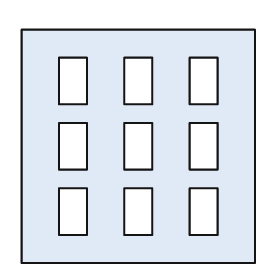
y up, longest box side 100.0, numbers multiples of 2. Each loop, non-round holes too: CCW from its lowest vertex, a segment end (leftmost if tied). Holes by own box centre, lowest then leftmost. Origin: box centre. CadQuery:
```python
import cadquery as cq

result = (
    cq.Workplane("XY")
    .moveTo(-50.0, -50.0)
    .lineTo(50.0, -50.0)
    .lineTo(50.0, 50.0)
    .lineTo(-50.0, 50.0)
    .close()
    .moveTo(-34.0, -38.0)
    .lineTo(-22.0, -38.0)
    .lineTo(-22.0, -18.0)
    .lineTo(-34.0, -18.0)
    .close()
    .moveTo(-6.0, -38.0)
    .lineTo(6.0, -38.0)
    .lineTo(6.0, -18.0)
    .lineTo(-6.0, -18.0)
    .close()
    .moveTo(22.0, -38.0)
    .lineTo(34.0, -38.0)
    .lineTo(34.0, -18.0)
    .lineTo(22.0, -18.0)
    .close()
    .moveTo(-34.0, -10.0)
    .lineTo(-22.0, -10.0)
    .lineTo(-22.0, 10.0)
    .lineTo(-34.0, 10.0)
    .close()
    .moveTo(-6.0, -10.0)
    .lineTo(6.0, -10.0)
    .lineTo(6.0, 10.0)
    .lineTo(-6.0, 10.0)
    .close()
    .moveTo(22.0, -10.0)
    .lineTo(34.0, -10.0)
    .lineTo(34.0, 10.0)
    .lineTo(22.0, 10.0)
    .close()
    .moveTo(-34.0, 18.0)
    .lineTo(-22.0, 18.0)
    .lineTo(-22.0, 38.0)
    .lineTo(-34.0, 38.0)
    .close()
    .moveTo(-6.0, 18.0)
    .lineTo(6.0, 18.0)
    .lineTo(6.0, 38.0)
    .lineTo(-6.0, 38.0)
    .close()
    .moveTo(22.0, 18.0)
    .lineTo(34.0, 18.0)
    .lineTo(34.0, 38.0)
    .lineTo(22.0, 38.0)
    .close()
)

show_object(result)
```